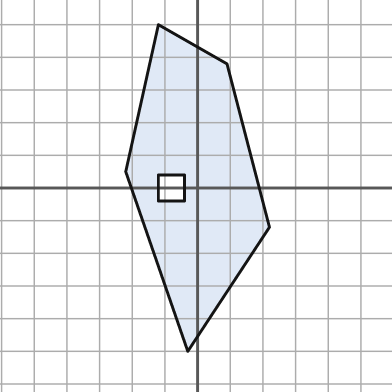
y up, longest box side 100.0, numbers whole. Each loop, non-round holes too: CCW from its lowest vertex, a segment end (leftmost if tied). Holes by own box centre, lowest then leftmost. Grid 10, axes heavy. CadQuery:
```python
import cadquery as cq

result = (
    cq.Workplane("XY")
    .moveTo(-3.0, -50.0)
    .lineTo(22.0, -12.0)
    .lineTo(9.0, 38.0)
    .lineTo(-12.0, 50.0)
    .lineTo(-22.0, 5.0)
    .close()
    .moveTo(-12.0, -4.0)
    .lineTo(-4.0, -4.0)
    .lineTo(-4.0, 4.0)
    .lineTo(-12.0, 4.0)
    .close()
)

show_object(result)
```